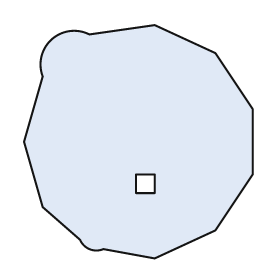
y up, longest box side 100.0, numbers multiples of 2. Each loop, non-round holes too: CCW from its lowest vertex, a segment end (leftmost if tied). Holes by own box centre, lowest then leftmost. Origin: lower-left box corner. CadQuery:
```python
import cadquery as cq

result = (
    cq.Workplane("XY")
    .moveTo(56.0, 0.0)
    .lineTo(82.0, 12.0)
    .lineTo(98.0, 36.0)
    .lineTo(98.0, 64.0)
    .lineTo(82.0, 88.0)
    .lineTo(56.0, 100.0)
    .lineTo(28.0, 96.0)
    .threePointArc((12.0, 94.0), (8.0, 78.0))
    .lineTo(0.0, 50.0)
    .lineTo(8.0, 22.0)
    .lineTo(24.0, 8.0)
    .threePointArc((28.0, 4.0), (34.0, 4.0))
    .close()
    .moveTo(48.0, 28.0)
    .lineTo(56.0, 28.0)
    .lineTo(56.0, 36.0)
    .lineTo(48.0, 36.0)
    .close()
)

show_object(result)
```